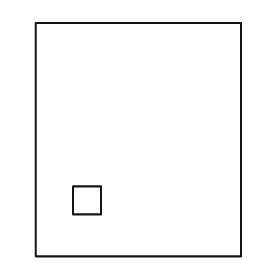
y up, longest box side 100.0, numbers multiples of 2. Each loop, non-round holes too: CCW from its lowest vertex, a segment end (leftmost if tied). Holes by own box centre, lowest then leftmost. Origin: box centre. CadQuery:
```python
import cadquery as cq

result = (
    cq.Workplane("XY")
    .moveTo(-44.0, -50.0)
    .lineTo(44.0, -50.0)
    .lineTo(44.0, 50.0)
    .lineTo(-44.0, 50.0)
    .close()
    .moveTo(-28.0, -32.0)
    .lineTo(-16.0, -32.0)
    .lineTo(-16.0, -20.0)
    .lineTo(-28.0, -20.0)
    .close()
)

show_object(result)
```